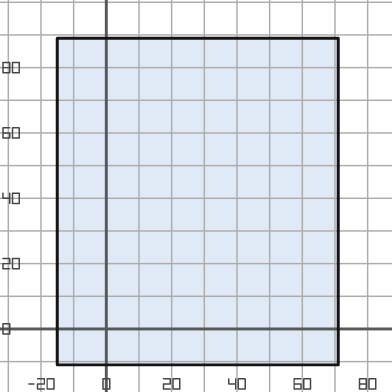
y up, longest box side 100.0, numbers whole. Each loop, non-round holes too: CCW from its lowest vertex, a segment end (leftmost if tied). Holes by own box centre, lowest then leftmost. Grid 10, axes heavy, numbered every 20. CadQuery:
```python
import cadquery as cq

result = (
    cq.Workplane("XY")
    .moveTo(-15.0, -11.0)
    .lineTo(71.0, -11.0)
    .lineTo(71.0, 89.0)
    .lineTo(-15.0, 89.0)
    .close()
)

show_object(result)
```